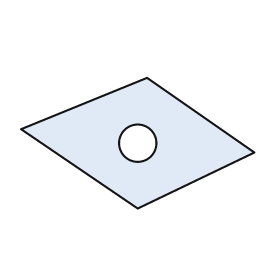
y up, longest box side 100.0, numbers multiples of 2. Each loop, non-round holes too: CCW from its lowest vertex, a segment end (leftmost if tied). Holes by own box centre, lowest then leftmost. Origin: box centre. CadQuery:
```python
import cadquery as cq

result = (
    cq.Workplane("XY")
    .moveTo(0.0, -28.0)
    .lineTo(50.0, -4.0)
    .lineTo(4.0, 28.0)
    .lineTo(-50.0, 6.0)
    .close()
    .moveTo(0.0, 0.0)
    .circle(8.0)
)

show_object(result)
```